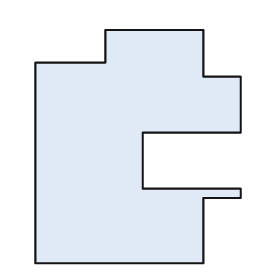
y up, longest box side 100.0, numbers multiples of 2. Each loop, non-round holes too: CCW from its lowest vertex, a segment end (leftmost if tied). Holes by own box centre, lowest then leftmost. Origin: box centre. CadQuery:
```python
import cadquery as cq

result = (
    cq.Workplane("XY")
    .moveTo(-44.0, -50.0)
    .lineTo(28.0, -50.0)
    .lineTo(28.0, -22.0)
    .lineTo(44.0, -22.0)
    .lineTo(44.0, -18.0)
    .lineTo(2.0, -18.0)
    .lineTo(2.0, 6.0)
    .lineTo(44.0, 6.0)
    .lineTo(44.0, 30.0)
    .lineTo(28.0, 30.0)
    .lineTo(28.0, 50.0)
    .lineTo(-14.0, 50.0)
    .lineTo(-14.0, 36.0)
    .lineTo(-44.0, 36.0)
    .close()
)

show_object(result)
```